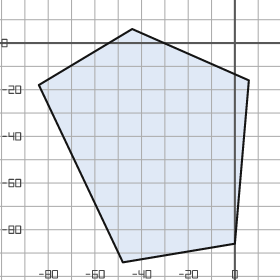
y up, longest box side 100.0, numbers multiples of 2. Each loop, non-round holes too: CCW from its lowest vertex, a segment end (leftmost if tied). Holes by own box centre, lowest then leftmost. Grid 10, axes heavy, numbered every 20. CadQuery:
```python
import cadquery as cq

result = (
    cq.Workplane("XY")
    .moveTo(-48.0, -94.0)
    .lineTo(0.0, -86.0)
    .lineTo(6.0, -16.0)
    .lineTo(-44.0, 6.0)
    .lineTo(-84.0, -18.0)
    .close()
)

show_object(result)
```